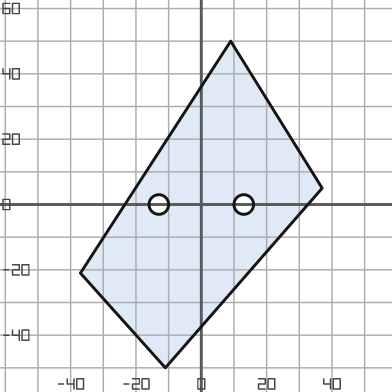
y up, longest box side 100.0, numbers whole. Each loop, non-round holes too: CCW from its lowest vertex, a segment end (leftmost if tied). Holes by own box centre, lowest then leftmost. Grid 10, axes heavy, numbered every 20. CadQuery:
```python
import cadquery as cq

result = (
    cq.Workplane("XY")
    .moveTo(-11.0, -50.0)
    .lineTo(37.0, 5.0)
    .lineTo(9.0, 50.0)
    .lineTo(-37.0, -21.0)
    .close()
    .moveTo(-13.0, 0.0)
    .circle(3.0)
    .moveTo(13.0, 0.0)
    .circle(3.0)
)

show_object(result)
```